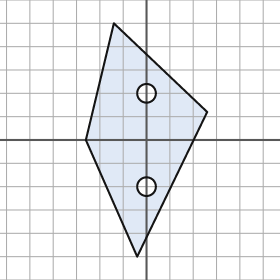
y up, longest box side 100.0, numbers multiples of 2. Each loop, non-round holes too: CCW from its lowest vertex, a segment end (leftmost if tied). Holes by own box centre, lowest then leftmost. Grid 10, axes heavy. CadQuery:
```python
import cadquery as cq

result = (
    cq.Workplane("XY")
    .moveTo(-4.0, -50.0)
    .lineTo(26.0, 12.0)
    .lineTo(-14.0, 50.0)
    .lineTo(-26.0, 0.0)
    .close()
    .moveTo(0.0, -20.0)
    .circle(4.0)
    .moveTo(0.0, 20.0)
    .circle(4.0)
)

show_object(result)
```